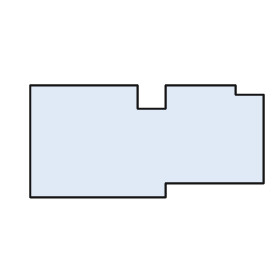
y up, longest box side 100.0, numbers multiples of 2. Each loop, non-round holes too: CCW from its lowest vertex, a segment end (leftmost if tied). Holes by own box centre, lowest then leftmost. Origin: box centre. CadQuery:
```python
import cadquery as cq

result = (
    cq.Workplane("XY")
    .moveTo(-50.0, -24.0)
    .lineTo(8.0, -24.0)
    .lineTo(8.0, -18.0)
    .lineTo(50.0, -18.0)
    .lineTo(50.0, 20.0)
    .lineTo(38.0, 20.0)
    .lineTo(38.0, 24.0)
    .lineTo(8.0, 24.0)
    .lineTo(8.0, 14.0)
    .lineTo(-4.0, 14.0)
    .lineTo(-4.0, 24.0)
    .lineTo(-50.0, 24.0)
    .close()
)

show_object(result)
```